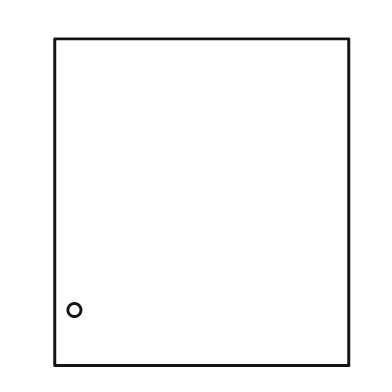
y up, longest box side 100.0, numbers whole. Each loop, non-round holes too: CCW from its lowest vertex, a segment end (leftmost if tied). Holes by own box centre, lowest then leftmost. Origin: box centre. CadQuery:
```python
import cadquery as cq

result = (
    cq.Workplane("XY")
    .moveTo(-45.0, -50.0)
    .lineTo(45.0, -50.0)
    .lineTo(45.0, 50.0)
    .lineTo(-45.0, 50.0)
    .close()
    .moveTo(-39.0, -33.0)
    .circle(2.0)
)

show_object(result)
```